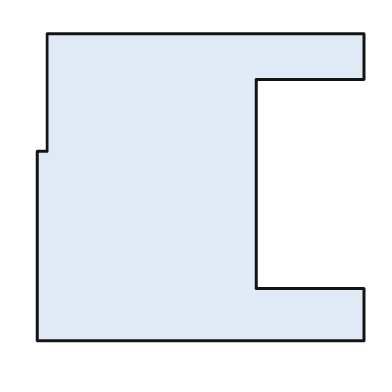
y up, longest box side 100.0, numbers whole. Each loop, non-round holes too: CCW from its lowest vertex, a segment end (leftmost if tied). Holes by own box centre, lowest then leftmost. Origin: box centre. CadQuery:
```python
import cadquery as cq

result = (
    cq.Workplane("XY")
    .moveTo(-50.0, -47.0)
    .lineTo(50.0, -47.0)
    .lineTo(50.0, -31.0)
    .lineTo(17.0, -31.0)
    .lineTo(17.0, 33.0)
    .lineTo(50.0, 33.0)
    .lineTo(50.0, 47.0)
    .lineTo(-47.0, 47.0)
    .lineTo(-47.0, 11.0)
    .lineTo(-50.0, 11.0)
    .close()
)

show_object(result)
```